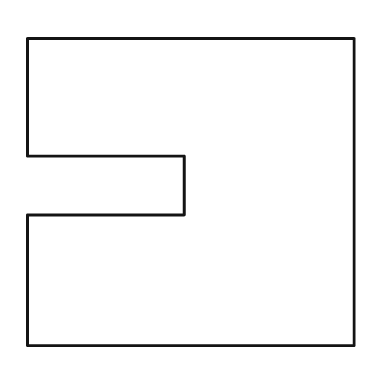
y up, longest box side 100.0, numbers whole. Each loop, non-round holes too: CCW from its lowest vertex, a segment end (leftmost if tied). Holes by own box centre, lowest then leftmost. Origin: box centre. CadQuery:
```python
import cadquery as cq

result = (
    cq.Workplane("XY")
    .moveTo(-50.0, -47.0)
    .lineTo(50.0, -47.0)
    .lineTo(50.0, 47.0)
    .lineTo(-50.0, 47.0)
    .lineTo(-50.0, 11.0)
    .lineTo(-2.0, 11.0)
    .lineTo(-2.0, -7.0)
    .lineTo(-50.0, -7.0)
    .close()
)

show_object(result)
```